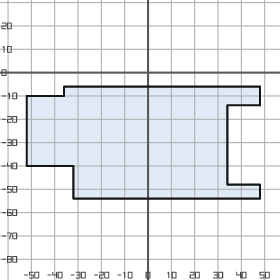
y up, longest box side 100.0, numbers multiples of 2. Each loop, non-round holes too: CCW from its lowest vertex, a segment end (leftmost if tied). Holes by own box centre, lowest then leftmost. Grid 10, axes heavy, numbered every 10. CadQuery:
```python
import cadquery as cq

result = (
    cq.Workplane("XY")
    .moveTo(-32.0, -54.0)
    .lineTo(48.0, -54.0)
    .lineTo(48.0, -48.0)
    .lineTo(34.0, -48.0)
    .lineTo(34.0, -14.0)
    .lineTo(48.0, -14.0)
    .lineTo(48.0, -6.0)
    .lineTo(-36.0, -6.0)
    .lineTo(-36.0, -10.0)
    .lineTo(-52.0, -10.0)
    .lineTo(-52.0, -40.0)
    .lineTo(-32.0, -40.0)
    .close()
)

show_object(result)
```